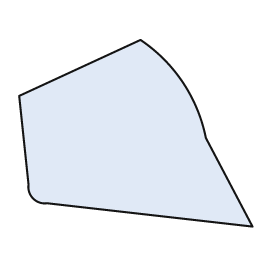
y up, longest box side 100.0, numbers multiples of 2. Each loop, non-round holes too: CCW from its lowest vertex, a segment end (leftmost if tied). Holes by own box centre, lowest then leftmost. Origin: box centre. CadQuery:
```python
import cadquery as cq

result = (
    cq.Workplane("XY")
    .moveTo(50.0, -40.0)
    .lineTo(30.0, -2.0)
    .threePointArc((20.0, 22.0), (2.0, 40.0))
    .lineTo(-50.0, 16.0)
    .lineTo(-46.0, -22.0)
    .threePointArc((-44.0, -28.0), (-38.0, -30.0))
    .close()
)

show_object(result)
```